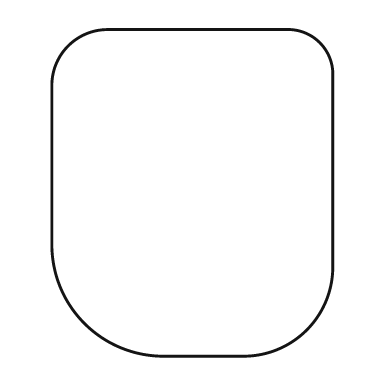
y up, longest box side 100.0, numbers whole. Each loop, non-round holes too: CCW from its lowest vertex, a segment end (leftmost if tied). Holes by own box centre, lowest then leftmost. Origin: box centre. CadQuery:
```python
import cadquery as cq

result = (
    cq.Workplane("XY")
    .moveTo(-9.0, -50.0)
    .lineTo(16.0, -50.0)
    .threePointArc((35.0, -42.0), (43.0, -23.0))
    .lineTo(43.0, 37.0)
    .threePointArc((39.0, 46.0), (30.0, 50.0))
    .lineTo(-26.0, 50.0)
    .threePointArc((-38.0, 45.0), (-43.0, 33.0))
    .lineTo(-43.0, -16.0)
    .threePointArc((-33.0, -40.0), (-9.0, -50.0))
    .close()
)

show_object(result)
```